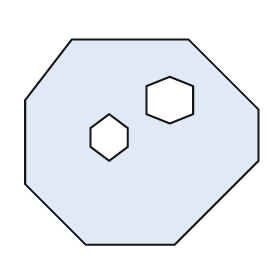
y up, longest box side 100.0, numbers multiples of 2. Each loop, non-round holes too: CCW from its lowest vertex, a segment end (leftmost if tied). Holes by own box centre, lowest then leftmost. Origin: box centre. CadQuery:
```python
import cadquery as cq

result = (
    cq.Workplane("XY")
    .moveTo(-24.0, -44.0)
    .lineTo(14.0, -44.0)
    .lineTo(50.0, -8.0)
    .lineTo(50.0, 14.0)
    .lineTo(20.0, 44.0)
    .lineTo(-30.0, 44.0)
    .lineTo(-50.0, 18.0)
    .lineTo(-50.0, -18.0)
    .close()
    .moveTo(-14.0, -8.0)
    .lineTo(-6.0, -2.0)
    .lineTo(-6.0, 6.0)
    .lineTo(-14.0, 12.0)
    .lineTo(-22.0, 6.0)
    .lineTo(-22.0, -2.0)
    .close()
    .moveTo(12.0, 8.0)
    .lineTo(22.0, 12.0)
    .lineTo(22.0, 24.0)
    .lineTo(12.0, 28.0)
    .lineTo(2.0, 24.0)
    .lineTo(2.0, 12.0)
    .close()
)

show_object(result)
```